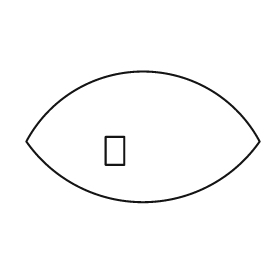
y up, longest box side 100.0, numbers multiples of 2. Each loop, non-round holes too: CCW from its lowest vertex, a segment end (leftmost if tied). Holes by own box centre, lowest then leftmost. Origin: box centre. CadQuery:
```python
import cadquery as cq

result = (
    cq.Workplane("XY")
    .moveTo(-50.0, -2.0)
    .threePointArc((0.0, -28.0), (50.0, -2.0))
    .threePointArc((0.0, 28.0), (-50.0, -2.0))
    .close()
    .moveTo(-16.0, -12.0)
    .lineTo(-8.0, -12.0)
    .lineTo(-8.0, 0.0)
    .lineTo(-16.0, 0.0)
    .close()
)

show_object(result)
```